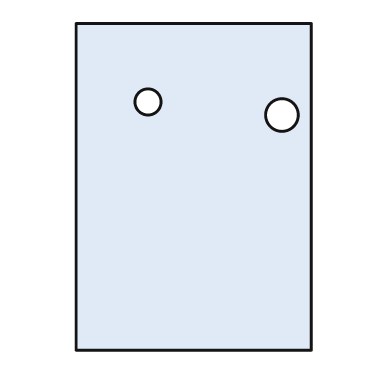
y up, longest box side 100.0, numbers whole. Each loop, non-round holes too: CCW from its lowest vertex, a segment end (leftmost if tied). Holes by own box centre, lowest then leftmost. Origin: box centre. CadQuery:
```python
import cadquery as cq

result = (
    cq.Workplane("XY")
    .moveTo(-36.0, -50.0)
    .lineTo(36.0, -50.0)
    .lineTo(36.0, 50.0)
    .lineTo(-36.0, 50.0)
    .close()
    .moveTo(27.0, 22.0)
    .circle(5.0)
    .moveTo(-14.0, 26.0)
    .circle(4.0)
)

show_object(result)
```